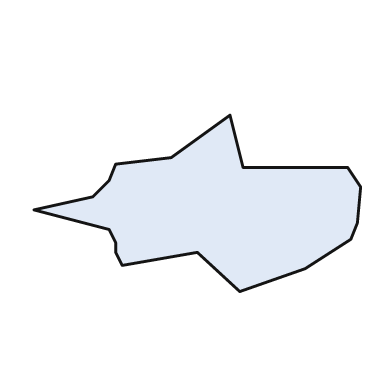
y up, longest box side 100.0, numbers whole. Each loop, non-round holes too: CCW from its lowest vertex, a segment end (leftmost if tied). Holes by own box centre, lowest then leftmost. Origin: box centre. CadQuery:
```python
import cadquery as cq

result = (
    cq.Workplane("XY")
    .moveTo(13.0, -27.0)
    .lineTo(33.0, -20.0)
    .lineTo(47.0, -11.0)
    .lineTo(49.0, -6.0)
    .lineTo(50.0, 5.0)
    .lineTo(46.0, 11.0)
    .lineTo(14.0, 11.0)
    .lineTo(10.0, 27.0)
    .lineTo(-8.0, 14.0)
    .lineTo(-25.0, 12.0)
    .lineTo(-27.0, 7.0)
    .lineTo(-32.0, 2.0)
    .lineTo(-50.0, -2.0)
    .lineTo(-27.0, -8.0)
    .lineTo(-25.0, -12.0)
    .lineTo(-25.0, -15.0)
    .lineTo(-23.0, -19.0)
    .lineTo(0.0, -15.0)
    .close()
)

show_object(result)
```